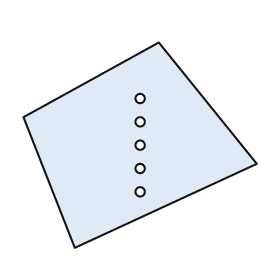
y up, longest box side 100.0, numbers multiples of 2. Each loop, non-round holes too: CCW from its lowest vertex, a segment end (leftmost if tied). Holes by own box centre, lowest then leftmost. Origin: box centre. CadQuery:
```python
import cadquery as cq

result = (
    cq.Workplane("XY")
    .moveTo(-28.0, -44.0)
    .lineTo(50.0, -8.0)
    .lineTo(8.0, 44.0)
    .lineTo(-50.0, 12.0)
    .close()
    .moveTo(0.0, -20.0)
    .circle(2.0)
    .moveTo(0.0, -10.0)
    .circle(2.0)
    .moveTo(0.0, 0.0)
    .circle(2.0)
    .moveTo(0.0, 10.0)
    .circle(2.0)
    .moveTo(0.0, 20.0)
    .circle(2.0)
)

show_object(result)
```